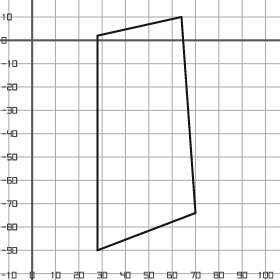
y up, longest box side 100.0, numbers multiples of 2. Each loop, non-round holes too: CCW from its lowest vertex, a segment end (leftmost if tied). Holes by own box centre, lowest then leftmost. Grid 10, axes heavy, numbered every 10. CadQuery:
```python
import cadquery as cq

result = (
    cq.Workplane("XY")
    .moveTo(28.0, -90.0)
    .lineTo(70.0, -74.0)
    .lineTo(64.0, 10.0)
    .lineTo(28.0, 2.0)
    .close()
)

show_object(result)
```